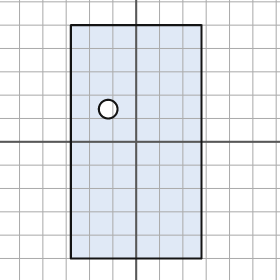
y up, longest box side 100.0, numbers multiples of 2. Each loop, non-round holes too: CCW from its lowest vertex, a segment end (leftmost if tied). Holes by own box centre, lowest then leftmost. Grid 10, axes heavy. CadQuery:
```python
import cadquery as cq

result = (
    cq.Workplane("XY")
    .moveTo(-28.0, -50.0)
    .lineTo(28.0, -50.0)
    .lineTo(28.0, 50.0)
    .lineTo(-28.0, 50.0)
    .close()
    .moveTo(-12.0, 14.0)
    .circle(4.0)
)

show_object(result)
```